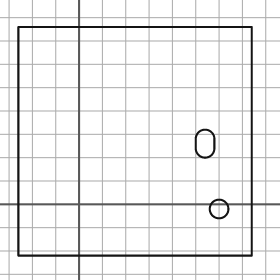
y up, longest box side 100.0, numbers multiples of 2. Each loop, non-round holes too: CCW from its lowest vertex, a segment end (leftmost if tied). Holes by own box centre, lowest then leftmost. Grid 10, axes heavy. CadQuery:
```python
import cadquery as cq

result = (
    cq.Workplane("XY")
    .moveTo(-26.0, -22.0)
    .lineTo(74.0, -22.0)
    .lineTo(74.0, 76.0)
    .lineTo(-26.0, 76.0)
    .close()
    .moveTo(60.0, -2.0)
    .circle(4.0)
    .moveTo(50.0, 24.0)
    .threePointArc((54.0, 20.0), (58.0, 24.0))
    .lineTo(58.0, 28.0)
    .threePointArc((54.0, 32.0), (50.0, 28.0))
    .close()
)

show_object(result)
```